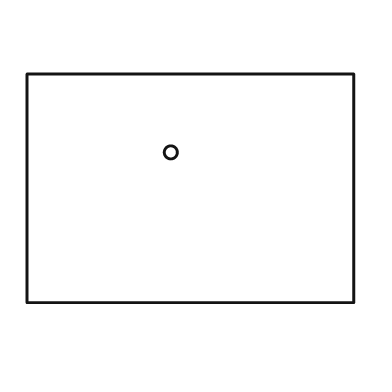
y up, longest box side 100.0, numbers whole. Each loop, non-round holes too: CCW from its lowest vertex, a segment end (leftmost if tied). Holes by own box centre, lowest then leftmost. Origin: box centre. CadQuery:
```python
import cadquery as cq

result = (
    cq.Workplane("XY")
    .moveTo(-50.0, -35.0)
    .lineTo(50.0, -35.0)
    .lineTo(50.0, 35.0)
    .lineTo(-50.0, 35.0)
    .close()
    .moveTo(-6.0, 11.0)
    .circle(2.0)
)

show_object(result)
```